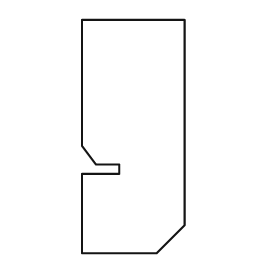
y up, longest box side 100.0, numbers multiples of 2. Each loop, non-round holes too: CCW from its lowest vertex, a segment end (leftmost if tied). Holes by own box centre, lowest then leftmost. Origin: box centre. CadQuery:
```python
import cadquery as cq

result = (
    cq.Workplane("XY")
    .moveTo(-22.0, -50.0)
    .lineTo(10.0, -50.0)
    .lineTo(22.0, -38.0)
    .lineTo(22.0, 50.0)
    .lineTo(-22.0, 50.0)
    .lineTo(-22.0, -4.0)
    .lineTo(-16.0, -12.0)
    .lineTo(-6.0, -12.0)
    .lineTo(-6.0, -16.0)
    .lineTo(-22.0, -16.0)
    .close()
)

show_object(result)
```